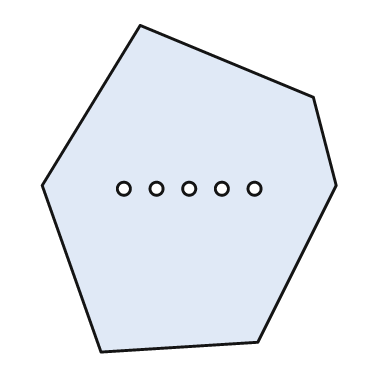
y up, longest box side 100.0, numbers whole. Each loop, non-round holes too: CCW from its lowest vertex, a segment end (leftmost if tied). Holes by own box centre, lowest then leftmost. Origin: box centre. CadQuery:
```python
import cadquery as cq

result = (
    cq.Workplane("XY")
    .moveTo(-27.0, -50.0)
    .lineTo(21.0, -47.0)
    .lineTo(45.0, 1.0)
    .lineTo(38.0, 28.0)
    .lineTo(-15.0, 50.0)
    .lineTo(-45.0, 1.0)
    .close()
    .moveTo(-20.0, 0.0)
    .circle(2.0)
    .moveTo(-10.0, 0.0)
    .circle(2.0)
    .moveTo(0.0, 0.0)
    .circle(2.0)
    .moveTo(10.0, 0.0)
    .circle(2.0)
    .moveTo(20.0, 0.0)
    .circle(2.0)
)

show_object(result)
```